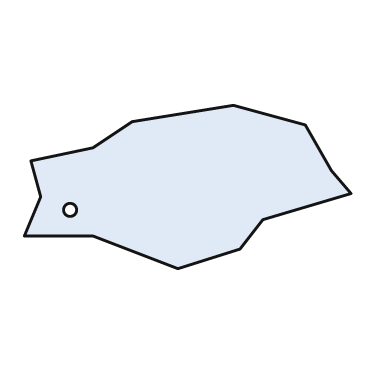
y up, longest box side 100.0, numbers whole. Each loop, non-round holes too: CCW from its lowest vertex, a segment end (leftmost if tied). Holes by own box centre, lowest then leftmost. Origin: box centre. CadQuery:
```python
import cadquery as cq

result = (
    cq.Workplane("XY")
    .moveTo(-3.0, -25.0)
    .lineTo(16.0, -19.0)
    .lineTo(23.0, -10.0)
    .lineTo(50.0, -2.0)
    .lineTo(44.0, 5.0)
    .lineTo(36.0, 19.0)
    .lineTo(14.0, 25.0)
    .lineTo(-17.0, 20.0)
    .lineTo(-29.0, 12.0)
    .lineTo(-48.0, 8.0)
    .lineTo(-45.0, -3.0)
    .lineTo(-50.0, -15.0)
    .lineTo(-29.0, -15.0)
    .close()
    .moveTo(-36.0, -7.0)
    .circle(2.0)
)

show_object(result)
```